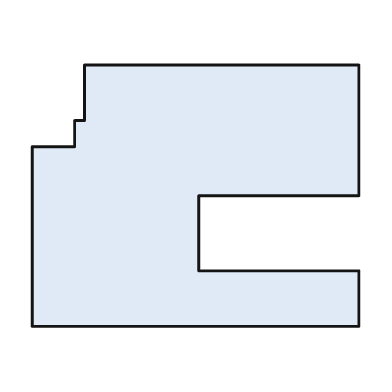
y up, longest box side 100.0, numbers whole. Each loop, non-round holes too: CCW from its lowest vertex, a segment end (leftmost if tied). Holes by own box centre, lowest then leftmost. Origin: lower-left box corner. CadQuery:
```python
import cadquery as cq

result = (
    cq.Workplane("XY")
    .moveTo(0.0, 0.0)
    .lineTo(100.0, 0.0)
    .lineTo(100.0, 17.0)
    .lineTo(51.0, 17.0)
    .lineTo(51.0, 40.0)
    .lineTo(100.0, 40.0)
    .lineTo(100.0, 80.0)
    .lineTo(16.0, 80.0)
    .lineTo(16.0, 63.0)
    .lineTo(13.0, 63.0)
    .lineTo(13.0, 55.0)
    .lineTo(0.0, 55.0)
    .close()
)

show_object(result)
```